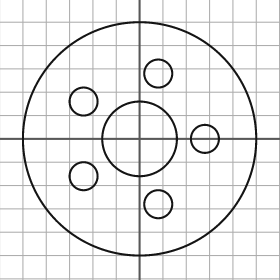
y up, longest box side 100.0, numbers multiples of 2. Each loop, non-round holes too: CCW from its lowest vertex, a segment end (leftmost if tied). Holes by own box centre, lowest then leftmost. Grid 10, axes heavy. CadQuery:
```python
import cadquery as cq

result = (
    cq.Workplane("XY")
    .moveTo(0.0, 0.0)
    .circle(50.0)
    .moveTo(8.0, -28.0)
    .circle(6.0)
    .moveTo(-24.0, -16.0)
    .circle(6.0)
    .moveTo(0.0, 0.0)
    .circle(16.0)
    .moveTo(28.0, 0.0)
    .circle(6.0)
    .moveTo(-24.0, 16.0)
    .circle(6.0)
    .moveTo(8.0, 28.0)
    .circle(6.0)
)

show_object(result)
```